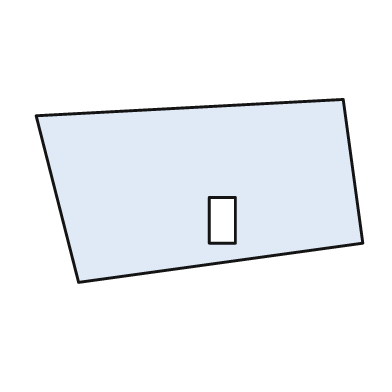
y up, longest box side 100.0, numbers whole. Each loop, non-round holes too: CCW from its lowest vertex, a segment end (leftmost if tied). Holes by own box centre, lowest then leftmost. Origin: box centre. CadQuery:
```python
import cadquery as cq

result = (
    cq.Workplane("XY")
    .moveTo(-37.0, -28.0)
    .lineTo(50.0, -16.0)
    .lineTo(44.0, 28.0)
    .lineTo(-50.0, 23.0)
    .close()
    .moveTo(3.0, -16.0)
    .lineTo(11.0, -16.0)
    .lineTo(11.0, -2.0)
    .lineTo(3.0, -2.0)
    .close()
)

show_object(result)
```